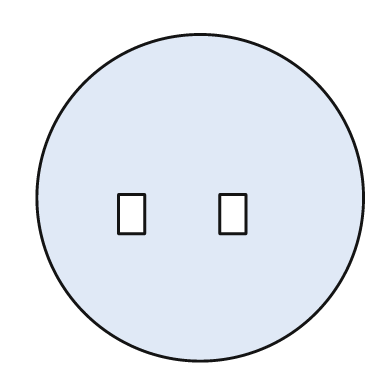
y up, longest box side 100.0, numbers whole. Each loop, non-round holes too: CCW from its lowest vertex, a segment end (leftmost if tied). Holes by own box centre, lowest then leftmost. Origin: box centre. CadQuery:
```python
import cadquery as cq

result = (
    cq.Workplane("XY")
    .moveTo(0.0, 0.0)
    .circle(50.0)
    .moveTo(-25.0, -11.0)
    .lineTo(-17.0, -11.0)
    .lineTo(-17.0, 1.0)
    .lineTo(-25.0, 1.0)
    .close()
    .moveTo(6.0, -11.0)
    .lineTo(14.0, -11.0)
    .lineTo(14.0, 1.0)
    .lineTo(6.0, 1.0)
    .close()
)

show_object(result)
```